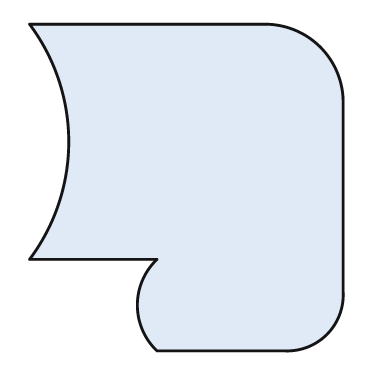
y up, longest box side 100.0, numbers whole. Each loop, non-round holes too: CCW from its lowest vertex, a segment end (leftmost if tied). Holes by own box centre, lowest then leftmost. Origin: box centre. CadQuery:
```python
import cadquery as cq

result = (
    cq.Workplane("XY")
    .moveTo(-9.0, -50.0)
    .lineTo(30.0, -50.0)
    .threePointArc((43.0, -45.0), (48.0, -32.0))
    .lineTo(48.0, 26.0)
    .threePointArc((41.0, 43.0), (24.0, 50.0))
    .lineTo(-48.0, 50.0)
    .threePointArc((-36.0, 14.0), (-48.0, -22.0))
    .lineTo(-9.0, -22.0)
    .threePointArc((-15.0, -36.0), (-9.0, -50.0))
    .close()
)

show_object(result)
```